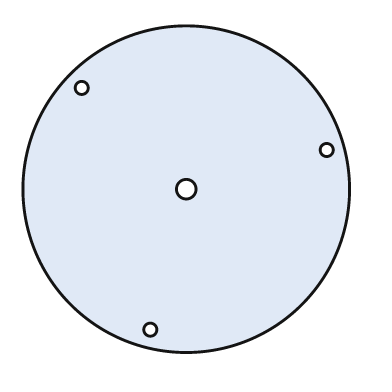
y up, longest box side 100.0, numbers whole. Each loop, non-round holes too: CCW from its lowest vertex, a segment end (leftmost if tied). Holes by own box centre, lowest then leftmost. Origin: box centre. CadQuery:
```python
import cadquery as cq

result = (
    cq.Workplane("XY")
    .moveTo(0.0, 0.0)
    .circle(50.0)
    .moveTo(-11.0, -43.0)
    .circle(2.0)
    .moveTo(0.0, 0.0)
    .circle(3.0)
    .moveTo(43.0, 12.0)
    .circle(2.0)
    .moveTo(-32.0, 31.0)
    .circle(2.0)
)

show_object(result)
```